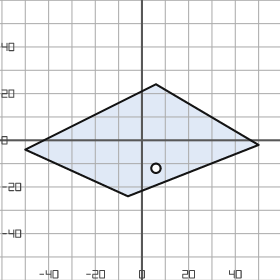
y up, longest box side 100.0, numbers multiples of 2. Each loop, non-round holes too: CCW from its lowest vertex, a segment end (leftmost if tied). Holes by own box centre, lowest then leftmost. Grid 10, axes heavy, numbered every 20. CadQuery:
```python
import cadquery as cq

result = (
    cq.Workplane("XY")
    .moveTo(-6.0, -24.0)
    .lineTo(50.0, -2.0)
    .lineTo(6.0, 24.0)
    .lineTo(-50.0, -4.0)
    .close()
    .moveTo(6.0, -12.0)
    .circle(2.0)
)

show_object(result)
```